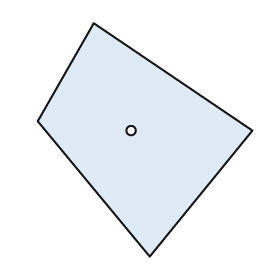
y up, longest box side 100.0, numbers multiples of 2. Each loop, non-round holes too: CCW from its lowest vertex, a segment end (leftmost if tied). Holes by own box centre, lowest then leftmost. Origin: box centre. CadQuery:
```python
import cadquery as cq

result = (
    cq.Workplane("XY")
    .moveTo(2.0, -50.0)
    .lineTo(46.0, 4.0)
    .lineTo(-22.0, 50.0)
    .lineTo(-46.0, 8.0)
    .close()
    .moveTo(-6.0, 4.0)
    .circle(2.0)
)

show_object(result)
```